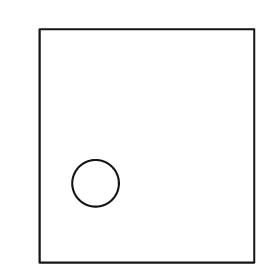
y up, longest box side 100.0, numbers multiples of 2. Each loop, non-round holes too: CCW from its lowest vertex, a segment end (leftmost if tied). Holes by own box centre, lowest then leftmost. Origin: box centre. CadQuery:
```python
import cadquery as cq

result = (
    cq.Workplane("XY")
    .moveTo(-46.0, -50.0)
    .lineTo(46.0, -50.0)
    .lineTo(46.0, 50.0)
    .lineTo(-46.0, 50.0)
    .close()
    .moveTo(-22.0, -16.0)
    .circle(10.0)
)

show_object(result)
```